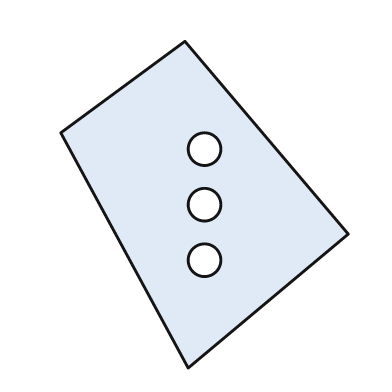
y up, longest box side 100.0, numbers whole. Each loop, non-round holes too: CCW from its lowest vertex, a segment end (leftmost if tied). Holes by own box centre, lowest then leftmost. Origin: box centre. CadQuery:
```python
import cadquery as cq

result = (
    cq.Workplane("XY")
    .moveTo(-5.0, -50.0)
    .lineTo(44.0, -9.0)
    .lineTo(-6.0, 50.0)
    .lineTo(-44.0, 22.0)
    .close()
    .moveTo(0.0, -17.0)
    .circle(5.0)
    .moveTo(0.0, 0.0)
    .circle(5.0)
    .moveTo(0.0, 17.0)
    .circle(5.0)
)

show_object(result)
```